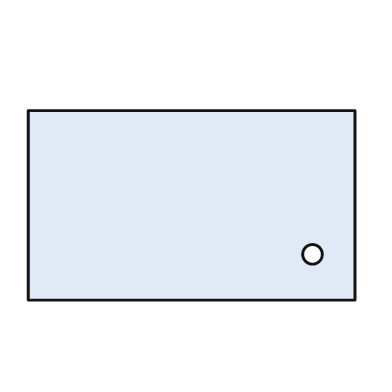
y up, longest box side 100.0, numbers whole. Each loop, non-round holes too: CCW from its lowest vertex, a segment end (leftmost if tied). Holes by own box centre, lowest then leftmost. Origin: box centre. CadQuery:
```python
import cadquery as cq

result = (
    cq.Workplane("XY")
    .moveTo(-50.0, -29.0)
    .lineTo(50.0, -29.0)
    .lineTo(50.0, 29.0)
    .lineTo(-50.0, 29.0)
    .close()
    .moveTo(37.0, -15.0)
    .circle(3.0)
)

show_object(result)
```